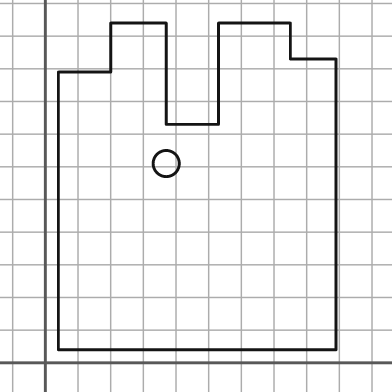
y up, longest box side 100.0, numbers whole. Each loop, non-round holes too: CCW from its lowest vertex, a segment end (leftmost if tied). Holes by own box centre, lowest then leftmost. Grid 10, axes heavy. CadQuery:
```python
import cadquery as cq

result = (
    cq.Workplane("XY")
    .moveTo(4.0, 4.0)
    .lineTo(89.0, 4.0)
    .lineTo(89.0, 93.0)
    .lineTo(75.0, 93.0)
    .lineTo(75.0, 104.0)
    .lineTo(53.0, 104.0)
    .lineTo(53.0, 73.0)
    .lineTo(37.0, 73.0)
    .lineTo(37.0, 104.0)
    .lineTo(20.0, 104.0)
    .lineTo(20.0, 89.0)
    .lineTo(4.0, 89.0)
    .close()
    .moveTo(37.0, 61.0)
    .circle(4.0)
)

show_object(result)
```